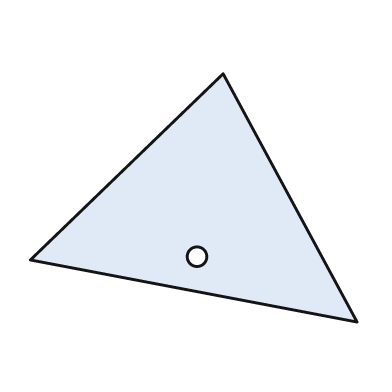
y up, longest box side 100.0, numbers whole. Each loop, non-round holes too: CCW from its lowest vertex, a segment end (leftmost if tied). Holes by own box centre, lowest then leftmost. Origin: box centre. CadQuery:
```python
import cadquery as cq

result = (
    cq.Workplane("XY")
    .moveTo(50.0, -38.0)
    .lineTo(9.0, 38.0)
    .lineTo(-50.0, -19.0)
    .close()
    .moveTo(1.0, -18.0)
    .circle(3.0)
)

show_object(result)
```